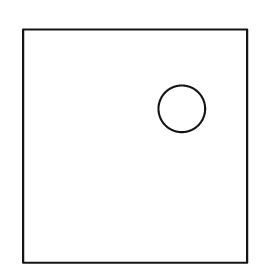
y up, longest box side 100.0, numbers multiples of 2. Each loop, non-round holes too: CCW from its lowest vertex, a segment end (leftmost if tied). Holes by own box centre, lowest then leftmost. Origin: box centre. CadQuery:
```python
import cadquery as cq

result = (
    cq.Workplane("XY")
    .moveTo(-48.0, -50.0)
    .lineTo(48.0, -50.0)
    .lineTo(48.0, 50.0)
    .lineTo(-48.0, 50.0)
    .close()
    .moveTo(20.0, 16.0)
    .circle(10.0)
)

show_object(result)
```